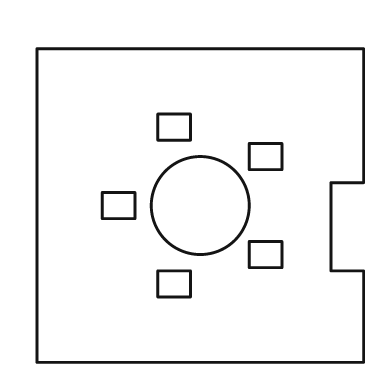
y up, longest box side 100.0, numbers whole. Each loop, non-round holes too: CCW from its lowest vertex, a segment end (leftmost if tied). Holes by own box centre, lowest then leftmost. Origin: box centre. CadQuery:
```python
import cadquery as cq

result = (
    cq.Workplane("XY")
    .moveTo(-50.0, -48.0)
    .lineTo(50.0, -48.0)
    .lineTo(50.0, -20.0)
    .lineTo(40.0, -20.0)
    .lineTo(40.0, 7.0)
    .lineTo(50.0, 7.0)
    .lineTo(50.0, 48.0)
    .lineTo(-50.0, 48.0)
    .close()
    .moveTo(-13.0, -28.0)
    .lineTo(-3.0, -28.0)
    .lineTo(-3.0, -20.0)
    .lineTo(-13.0, -20.0)
    .close()
    .moveTo(15.0, -19.0)
    .lineTo(25.0, -19.0)
    .lineTo(25.0, -11.0)
    .lineTo(15.0, -11.0)
    .close()
    .moveTo(-30.0, -4.0)
    .lineTo(-20.0, -4.0)
    .lineTo(-20.0, 4.0)
    .lineTo(-30.0, 4.0)
    .close()
    .moveTo(0.0, 0.0)
    .circle(15.0)
    .moveTo(15.0, 11.0)
    .lineTo(25.0, 11.0)
    .lineTo(25.0, 19.0)
    .lineTo(15.0, 19.0)
    .close()
    .moveTo(-13.0, 20.0)
    .lineTo(-3.0, 20.0)
    .lineTo(-3.0, 28.0)
    .lineTo(-13.0, 28.0)
    .close()
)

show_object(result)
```